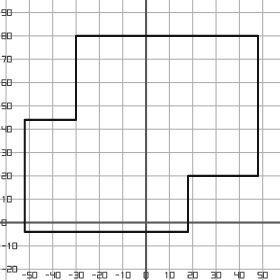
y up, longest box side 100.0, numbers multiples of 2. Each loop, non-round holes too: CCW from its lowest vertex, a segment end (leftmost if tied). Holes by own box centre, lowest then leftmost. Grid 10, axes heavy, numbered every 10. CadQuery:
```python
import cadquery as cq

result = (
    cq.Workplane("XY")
    .moveTo(-52.0, -4.0)
    .lineTo(18.0, -4.0)
    .lineTo(18.0, 20.0)
    .lineTo(48.0, 20.0)
    .lineTo(48.0, 80.0)
    .lineTo(-30.0, 80.0)
    .lineTo(-30.0, 44.0)
    .lineTo(-52.0, 44.0)
    .close()
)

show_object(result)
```